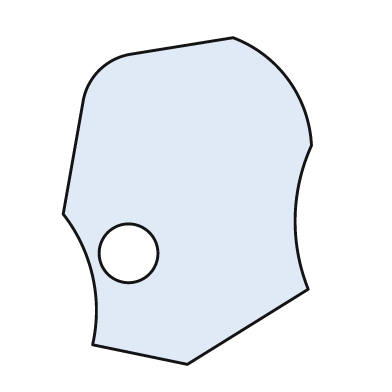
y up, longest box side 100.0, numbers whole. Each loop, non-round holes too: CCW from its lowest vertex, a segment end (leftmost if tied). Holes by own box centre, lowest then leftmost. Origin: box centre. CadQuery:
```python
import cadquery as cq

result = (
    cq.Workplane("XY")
    .moveTo(0.0, -50.0)
    .lineTo(37.0, -27.0)
    .threePointArc((33.0, -5.0), (38.0, 17.0))
    .threePointArc((31.0, 37.0), (14.0, 50.0))
    .lineTo(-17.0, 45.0)
    .threePointArc((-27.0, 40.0), (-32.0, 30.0))
    .lineTo(-38.0, -4.0)
    .threePointArc((-29.0, -23.0), (-29.0, -44.0))
    .close()
    .moveTo(-18.0, -16.0)
    .circle(9.0)
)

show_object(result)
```